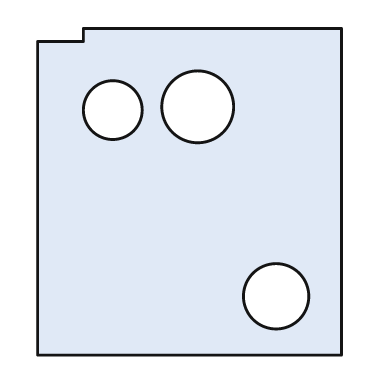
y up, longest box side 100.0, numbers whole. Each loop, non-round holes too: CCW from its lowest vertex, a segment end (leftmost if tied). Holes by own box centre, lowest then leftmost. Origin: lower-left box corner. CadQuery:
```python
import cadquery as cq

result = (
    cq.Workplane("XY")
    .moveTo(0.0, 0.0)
    .lineTo(93.0, 0.0)
    .lineTo(93.0, 100.0)
    .lineTo(14.0, 100.0)
    .lineTo(14.0, 96.0)
    .lineTo(0.0, 96.0)
    .close()
    .moveTo(73.0, 18.0)
    .circle(10.0)
    .moveTo(23.0, 75.0)
    .circle(9.0)
    .moveTo(49.0, 76.0)
    .circle(11.0)
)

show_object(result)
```